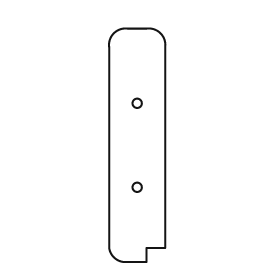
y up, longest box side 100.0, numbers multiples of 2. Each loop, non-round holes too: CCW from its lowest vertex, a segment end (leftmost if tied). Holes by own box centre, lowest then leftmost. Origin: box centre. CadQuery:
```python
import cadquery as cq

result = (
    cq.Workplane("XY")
    .moveTo(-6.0, -50.0)
    .lineTo(4.0, -50.0)
    .lineTo(4.0, -44.0)
    .lineTo(12.0, -44.0)
    .lineTo(12.0, 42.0)
    .threePointArc((10.0, 48.0), (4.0, 50.0))
    .lineTo(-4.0, 50.0)
    .threePointArc((-10.0, 48.0), (-12.0, 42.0))
    .lineTo(-12.0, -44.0)
    .threePointArc((-10.0, -48.0), (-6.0, -50.0))
    .close()
    .moveTo(0.0, -18.0)
    .circle(2.0)
    .moveTo(0.0, 18.0)
    .circle(2.0)
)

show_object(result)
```